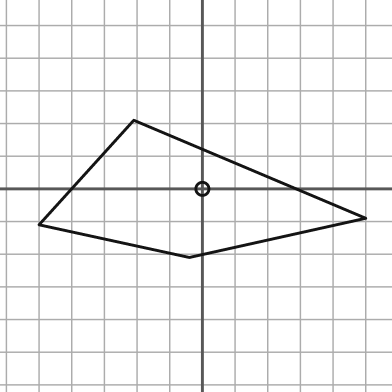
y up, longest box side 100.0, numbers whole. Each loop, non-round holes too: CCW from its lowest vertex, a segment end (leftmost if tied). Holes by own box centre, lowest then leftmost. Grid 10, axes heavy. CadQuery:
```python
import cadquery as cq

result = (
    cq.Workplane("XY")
    .moveTo(-4.0, -21.0)
    .lineTo(50.0, -9.0)
    .lineTo(-21.0, 21.0)
    .lineTo(-50.0, -11.0)
    .close()
    .moveTo(0.0, 0.0)
    .circle(2.0)
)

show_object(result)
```